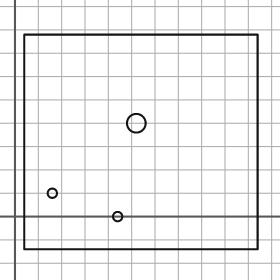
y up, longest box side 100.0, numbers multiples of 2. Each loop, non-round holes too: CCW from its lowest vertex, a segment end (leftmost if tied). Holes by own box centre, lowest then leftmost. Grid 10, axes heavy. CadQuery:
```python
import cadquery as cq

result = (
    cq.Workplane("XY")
    .moveTo(4.0, -14.0)
    .lineTo(104.0, -14.0)
    .lineTo(104.0, 78.0)
    .lineTo(4.0, 78.0)
    .close()
    .moveTo(44.0, 0.0)
    .circle(2.0)
    .moveTo(16.0, 10.0)
    .circle(2.0)
    .moveTo(52.0, 40.0)
    .circle(4.0)
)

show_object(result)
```